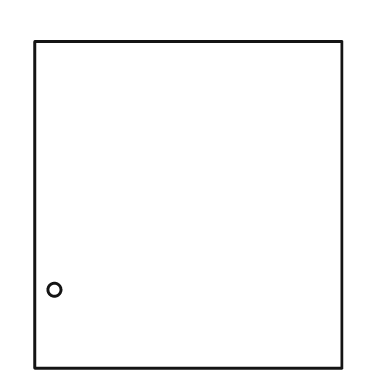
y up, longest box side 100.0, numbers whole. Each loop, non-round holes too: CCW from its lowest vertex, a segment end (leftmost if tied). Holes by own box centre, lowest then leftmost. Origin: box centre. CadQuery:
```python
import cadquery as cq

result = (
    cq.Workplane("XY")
    .moveTo(-47.0, -50.0)
    .lineTo(47.0, -50.0)
    .lineTo(47.0, 50.0)
    .lineTo(-47.0, 50.0)
    .close()
    .moveTo(-41.0, -26.0)
    .circle(2.0)
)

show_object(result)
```